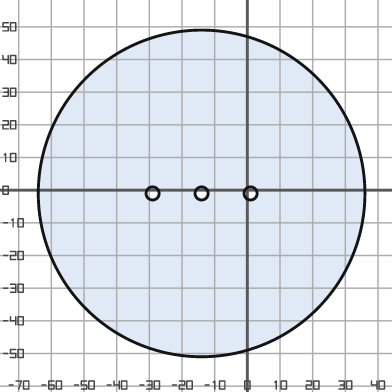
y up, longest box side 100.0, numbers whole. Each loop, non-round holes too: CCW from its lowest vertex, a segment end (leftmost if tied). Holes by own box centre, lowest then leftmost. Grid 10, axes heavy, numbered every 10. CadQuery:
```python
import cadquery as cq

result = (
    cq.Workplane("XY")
    .moveTo(-14.0, -1.0)
    .circle(50.0)
    .moveTo(-29.0, -1.0)
    .circle(2.0)
    .moveTo(-14.0, -1.0)
    .circle(2.0)
    .moveTo(1.0, -1.0)
    .circle(2.0)
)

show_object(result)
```